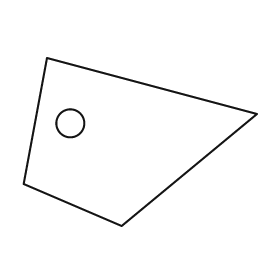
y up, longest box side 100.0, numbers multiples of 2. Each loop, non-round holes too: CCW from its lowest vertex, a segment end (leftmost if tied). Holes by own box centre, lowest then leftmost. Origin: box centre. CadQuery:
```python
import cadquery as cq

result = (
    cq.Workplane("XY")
    .moveTo(-8.0, -36.0)
    .lineTo(50.0, 12.0)
    .lineTo(-40.0, 36.0)
    .lineTo(-50.0, -18.0)
    .close()
    .moveTo(-30.0, 8.0)
    .circle(6.0)
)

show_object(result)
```